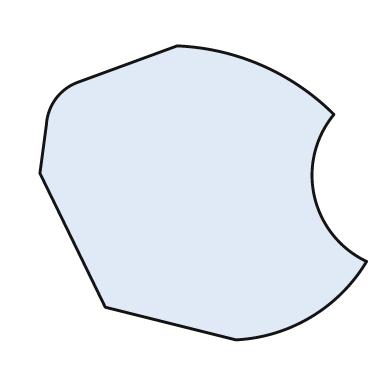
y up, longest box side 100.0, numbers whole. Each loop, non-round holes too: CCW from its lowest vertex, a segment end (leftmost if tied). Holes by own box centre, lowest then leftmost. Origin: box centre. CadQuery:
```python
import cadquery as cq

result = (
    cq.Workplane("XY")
    .moveTo(10.0, -45.0)
    .threePointArc((33.0, -38.0), (50.0, -21.0))
    .threePointArc((34.0, -1.0), (40.0, 24.0))
    .threePointArc((18.0, 39.0), (-8.0, 45.0))
    .lineTo(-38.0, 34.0)
    .threePointArc((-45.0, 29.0), (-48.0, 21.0))
    .lineTo(-50.0, 6.0)
    .lineTo(-30.0, -35.0)
    .close()
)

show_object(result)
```